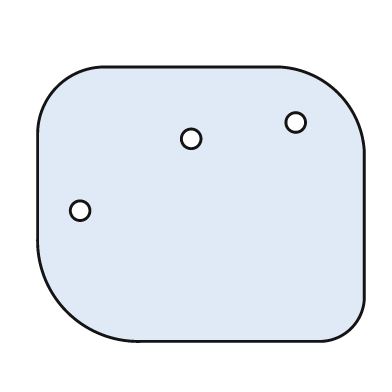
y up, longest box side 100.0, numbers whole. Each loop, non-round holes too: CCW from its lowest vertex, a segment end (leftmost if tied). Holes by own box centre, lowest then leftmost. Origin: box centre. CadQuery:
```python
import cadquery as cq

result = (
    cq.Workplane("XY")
    .moveTo(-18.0, -42.0)
    .lineTo(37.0, -42.0)
    .threePointArc((46.0, -38.0), (50.0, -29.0))
    .lineTo(50.0, 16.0)
    .threePointArc((42.0, 34.0), (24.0, 42.0))
    .lineTo(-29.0, 42.0)
    .threePointArc((-44.0, 36.0), (-50.0, 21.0))
    .lineTo(-50.0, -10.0)
    .threePointArc((-41.0, -33.0), (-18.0, -42.0))
    .close()
    .moveTo(-37.0, -2.0)
    .circle(3.0)
    .moveTo(-3.0, 20.0)
    .circle(3.0)
    .moveTo(29.0, 25.0)
    .circle(3.0)
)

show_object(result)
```